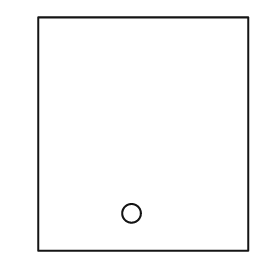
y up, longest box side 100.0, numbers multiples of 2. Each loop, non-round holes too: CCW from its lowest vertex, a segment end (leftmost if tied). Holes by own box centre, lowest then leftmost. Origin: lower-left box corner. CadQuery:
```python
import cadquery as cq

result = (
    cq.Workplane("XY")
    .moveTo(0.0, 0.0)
    .lineTo(90.0, 0.0)
    .lineTo(90.0, 100.0)
    .lineTo(0.0, 100.0)
    .close()
    .moveTo(40.0, 16.0)
    .circle(4.0)
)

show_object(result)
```